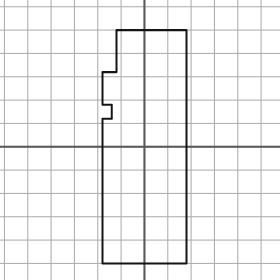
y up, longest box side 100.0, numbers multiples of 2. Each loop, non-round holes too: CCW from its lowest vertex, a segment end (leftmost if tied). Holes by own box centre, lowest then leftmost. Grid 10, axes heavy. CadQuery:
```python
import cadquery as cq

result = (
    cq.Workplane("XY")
    .moveTo(-18.0, -50.0)
    .lineTo(18.0, -50.0)
    .lineTo(18.0, 50.0)
    .lineTo(-12.0, 50.0)
    .lineTo(-12.0, 32.0)
    .lineTo(-18.0, 32.0)
    .lineTo(-18.0, 18.0)
    .lineTo(-14.0, 18.0)
    .lineTo(-14.0, 12.0)
    .lineTo(-18.0, 12.0)
    .close()
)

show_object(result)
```